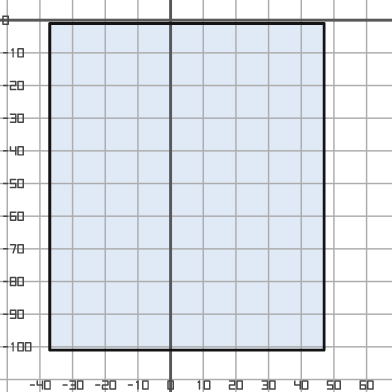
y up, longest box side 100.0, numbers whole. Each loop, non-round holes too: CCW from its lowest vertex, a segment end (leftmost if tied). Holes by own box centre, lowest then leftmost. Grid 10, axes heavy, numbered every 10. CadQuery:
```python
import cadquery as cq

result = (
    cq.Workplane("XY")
    .moveTo(-37.0, -101.0)
    .lineTo(47.0, -101.0)
    .lineTo(47.0, -1.0)
    .lineTo(-37.0, -1.0)
    .close()
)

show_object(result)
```